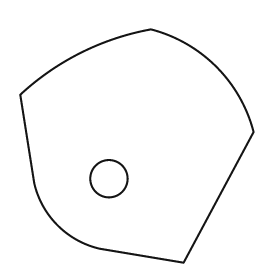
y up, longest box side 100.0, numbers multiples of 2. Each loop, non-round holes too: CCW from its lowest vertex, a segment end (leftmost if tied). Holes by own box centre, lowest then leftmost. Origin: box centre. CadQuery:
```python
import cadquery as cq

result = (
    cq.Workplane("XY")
    .moveTo(20.0, -50.0)
    .lineTo(50.0, 6.0)
    .threePointArc((34.0, 34.0), (6.0, 50.0))
    .threePointArc((-24.0, 40.0), (-50.0, 22.0))
    .lineTo(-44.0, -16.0)
    .threePointArc((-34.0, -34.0), (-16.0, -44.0))
    .close()
    .moveTo(-12.0, -14.0)
    .circle(8.0)
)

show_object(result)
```